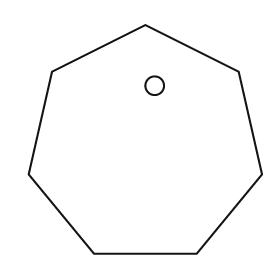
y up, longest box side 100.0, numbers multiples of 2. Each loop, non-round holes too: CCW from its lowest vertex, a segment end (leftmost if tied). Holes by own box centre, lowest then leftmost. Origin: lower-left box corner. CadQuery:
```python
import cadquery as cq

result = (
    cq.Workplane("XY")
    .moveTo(28.0, 0.0)
    .lineTo(72.0, 0.0)
    .lineTo(100.0, 34.0)
    .lineTo(90.0, 78.0)
    .lineTo(50.0, 98.0)
    .lineTo(10.0, 78.0)
    .lineTo(0.0, 34.0)
    .close()
    .moveTo(54.0, 72.0)
    .circle(4.0)
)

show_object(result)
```